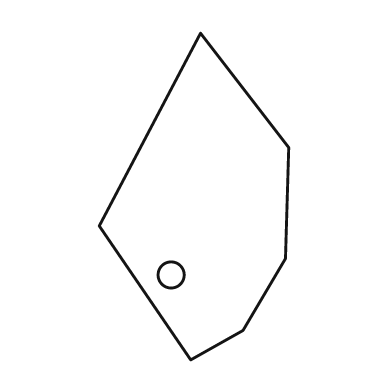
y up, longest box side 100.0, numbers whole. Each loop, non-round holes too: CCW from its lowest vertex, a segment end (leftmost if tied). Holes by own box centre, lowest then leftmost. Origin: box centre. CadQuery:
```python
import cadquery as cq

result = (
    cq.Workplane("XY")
    .moveTo(-1.0, -50.0)
    .lineTo(15.0, -41.0)
    .lineTo(28.0, -19.0)
    .lineTo(29.0, 15.0)
    .lineTo(2.0, 50.0)
    .lineTo(-29.0, -9.0)
    .close()
    .moveTo(-7.0, -24.0)
    .circle(4.0)
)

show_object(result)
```